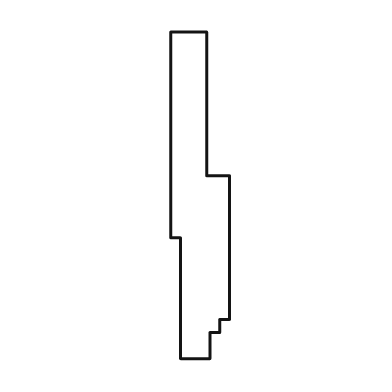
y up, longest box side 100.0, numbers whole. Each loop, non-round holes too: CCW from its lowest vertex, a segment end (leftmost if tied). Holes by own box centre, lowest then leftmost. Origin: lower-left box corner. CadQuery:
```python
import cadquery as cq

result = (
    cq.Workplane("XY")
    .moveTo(3.0, 0.0)
    .lineTo(12.0, 0.0)
    .lineTo(12.0, 8.0)
    .lineTo(15.0, 8.0)
    .lineTo(15.0, 12.0)
    .lineTo(18.0, 12.0)
    .lineTo(18.0, 56.0)
    .lineTo(11.0, 56.0)
    .lineTo(11.0, 100.0)
    .lineTo(0.0, 100.0)
    .lineTo(0.0, 37.0)
    .lineTo(3.0, 37.0)
    .close()
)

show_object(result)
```